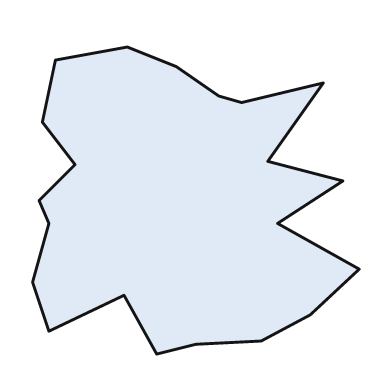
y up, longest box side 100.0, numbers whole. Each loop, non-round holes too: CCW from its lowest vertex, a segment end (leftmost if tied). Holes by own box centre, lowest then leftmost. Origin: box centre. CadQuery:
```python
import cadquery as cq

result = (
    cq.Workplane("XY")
    .moveTo(-12.0, -47.0)
    .lineTo(0.0, -44.0)
    .lineTo(20.0, -43.0)
    .lineTo(35.0, -35.0)
    .lineTo(50.0, -21.0)
    .lineTo(25.0, -7.0)
    .lineTo(45.0, 6.0)
    .lineTo(22.0, 12.0)
    .lineTo(39.0, 36.0)
    .lineTo(14.0, 30.0)
    .lineTo(7.0, 32.0)
    .lineTo(-6.0, 41.0)
    .lineTo(-21.0, 47.0)
    .lineTo(-43.0, 43.0)
    .lineTo(-47.0, 24.0)
    .lineTo(-37.0, 11.0)
    .lineTo(-48.0, 0.0)
    .lineTo(-45.0, -7.0)
    .lineTo(-50.0, -25.0)
    .lineTo(-45.0, -40.0)
    .lineTo(-22.0, -29.0)
    .close()
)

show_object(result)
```